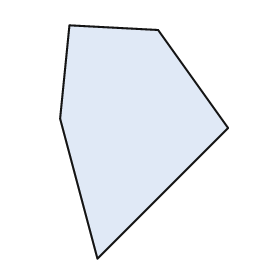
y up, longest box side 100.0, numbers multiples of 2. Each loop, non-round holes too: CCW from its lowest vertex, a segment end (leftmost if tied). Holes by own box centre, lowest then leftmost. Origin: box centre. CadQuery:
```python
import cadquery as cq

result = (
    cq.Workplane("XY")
    .moveTo(-20.0, -50.0)
    .lineTo(36.0, 6.0)
    .lineTo(6.0, 48.0)
    .lineTo(-32.0, 50.0)
    .lineTo(-36.0, 10.0)
    .close()
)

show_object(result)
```